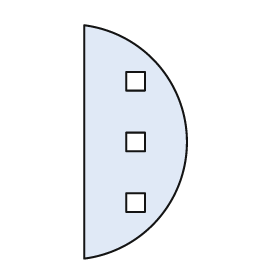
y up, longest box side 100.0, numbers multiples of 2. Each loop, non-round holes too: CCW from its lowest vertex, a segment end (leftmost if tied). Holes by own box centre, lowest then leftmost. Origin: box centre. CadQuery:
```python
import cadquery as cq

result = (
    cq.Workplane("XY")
    .moveTo(-22.0, -50.0)
    .threePointArc((22.0, 0.0), (-22.0, 50.0))
    .close()
    .moveTo(-4.0, -30.0)
    .lineTo(4.0, -30.0)
    .lineTo(4.0, -22.0)
    .lineTo(-4.0, -22.0)
    .close()
    .moveTo(-4.0, -4.0)
    .lineTo(4.0, -4.0)
    .lineTo(4.0, 4.0)
    .lineTo(-4.0, 4.0)
    .close()
    .moveTo(-4.0, 22.0)
    .lineTo(4.0, 22.0)
    .lineTo(4.0, 30.0)
    .lineTo(-4.0, 30.0)
    .close()
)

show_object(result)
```